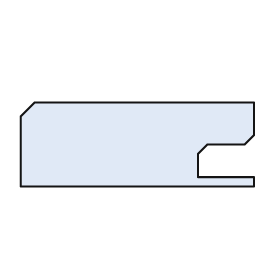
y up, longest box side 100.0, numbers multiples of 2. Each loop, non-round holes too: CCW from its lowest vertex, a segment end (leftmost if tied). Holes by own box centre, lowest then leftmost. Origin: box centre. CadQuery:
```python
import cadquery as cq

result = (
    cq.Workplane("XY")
    .moveTo(-50.0, -18.0)
    .lineTo(50.0, -18.0)
    .lineTo(50.0, -14.0)
    .lineTo(26.0, -14.0)
    .lineTo(26.0, -4.0)
    .lineTo(30.0, 0.0)
    .lineTo(46.0, 0.0)
    .lineTo(50.0, 4.0)
    .lineTo(50.0, 18.0)
    .lineTo(-44.0, 18.0)
    .lineTo(-50.0, 12.0)
    .close()
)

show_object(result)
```